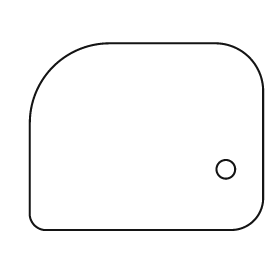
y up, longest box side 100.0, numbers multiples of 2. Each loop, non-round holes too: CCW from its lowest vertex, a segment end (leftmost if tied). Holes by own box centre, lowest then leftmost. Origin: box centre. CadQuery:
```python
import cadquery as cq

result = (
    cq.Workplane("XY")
    .moveTo(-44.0, -40.0)
    .lineTo(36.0, -40.0)
    .threePointArc((46.0, -36.0), (50.0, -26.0))
    .lineTo(50.0, 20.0)
    .threePointArc((44.0, 34.0), (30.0, 40.0))
    .lineTo(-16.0, 40.0)
    .threePointArc((-40.0, 30.0), (-50.0, 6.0))
    .lineTo(-50.0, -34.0)
    .threePointArc((-48.0, -38.0), (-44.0, -40.0))
    .close()
    .moveTo(34.0, -14.0)
    .circle(4.0)
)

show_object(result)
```